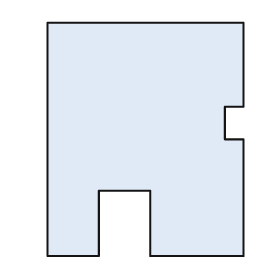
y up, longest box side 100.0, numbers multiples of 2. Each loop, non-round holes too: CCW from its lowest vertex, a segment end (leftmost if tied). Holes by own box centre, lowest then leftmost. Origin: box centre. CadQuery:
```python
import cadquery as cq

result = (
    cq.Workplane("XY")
    .moveTo(-42.0, -50.0)
    .lineTo(-20.0, -50.0)
    .lineTo(-20.0, -22.0)
    .lineTo(2.0, -22.0)
    .lineTo(2.0, -50.0)
    .lineTo(42.0, -50.0)
    .lineTo(42.0, 0.0)
    .lineTo(34.0, 0.0)
    .lineTo(34.0, 14.0)
    .lineTo(42.0, 14.0)
    .lineTo(42.0, 50.0)
    .lineTo(-42.0, 50.0)
    .close()
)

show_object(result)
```